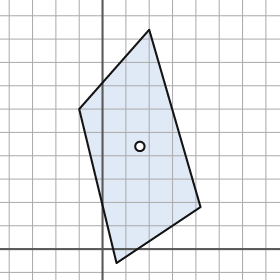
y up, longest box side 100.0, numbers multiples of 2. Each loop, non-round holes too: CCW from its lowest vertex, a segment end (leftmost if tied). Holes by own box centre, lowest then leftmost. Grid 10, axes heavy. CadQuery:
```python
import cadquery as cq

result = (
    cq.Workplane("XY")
    .moveTo(6.0, -6.0)
    .lineTo(42.0, 18.0)
    .lineTo(20.0, 94.0)
    .lineTo(-10.0, 60.0)
    .close()
    .moveTo(16.0, 44.0)
    .circle(2.0)
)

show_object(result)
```